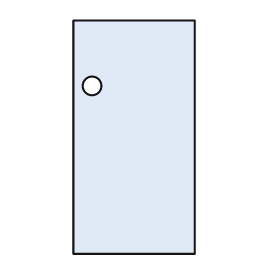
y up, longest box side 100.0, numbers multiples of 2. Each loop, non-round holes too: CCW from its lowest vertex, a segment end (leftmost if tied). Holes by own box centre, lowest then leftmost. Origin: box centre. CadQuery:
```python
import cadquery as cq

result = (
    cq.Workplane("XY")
    .moveTo(-26.0, -50.0)
    .lineTo(26.0, -50.0)
    .lineTo(26.0, 50.0)
    .lineTo(-26.0, 50.0)
    .close()
    .moveTo(-18.0, 22.0)
    .circle(4.0)
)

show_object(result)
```